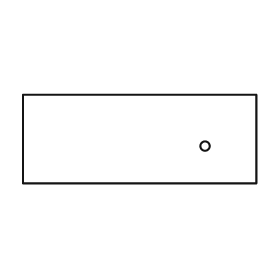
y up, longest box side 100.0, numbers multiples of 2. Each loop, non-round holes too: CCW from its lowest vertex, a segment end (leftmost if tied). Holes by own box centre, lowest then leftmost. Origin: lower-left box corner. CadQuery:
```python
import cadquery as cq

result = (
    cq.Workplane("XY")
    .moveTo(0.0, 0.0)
    .lineTo(100.0, 0.0)
    .lineTo(100.0, 38.0)
    .lineTo(0.0, 38.0)
    .close()
    .moveTo(78.0, 16.0)
    .circle(2.0)
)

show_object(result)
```